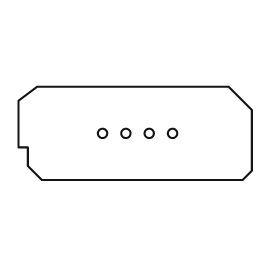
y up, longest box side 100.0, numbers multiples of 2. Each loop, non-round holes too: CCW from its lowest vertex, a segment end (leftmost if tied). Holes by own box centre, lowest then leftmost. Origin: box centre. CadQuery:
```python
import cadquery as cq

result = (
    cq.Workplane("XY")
    .moveTo(-40.0, -20.0)
    .lineTo(46.0, -20.0)
    .lineTo(50.0, -16.0)
    .lineTo(50.0, 10.0)
    .lineTo(40.0, 20.0)
    .lineTo(-42.0, 20.0)
    .lineTo(-50.0, 14.0)
    .lineTo(-50.0, -6.0)
    .lineTo(-46.0, -6.0)
    .lineTo(-46.0, -14.0)
    .close()
    .moveTo(-14.0, 0.0)
    .circle(2.0)
    .moveTo(-4.0, 0.0)
    .circle(2.0)
    .moveTo(6.0, 0.0)
    .circle(2.0)
    .moveTo(16.0, 0.0)
    .circle(2.0)
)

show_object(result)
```